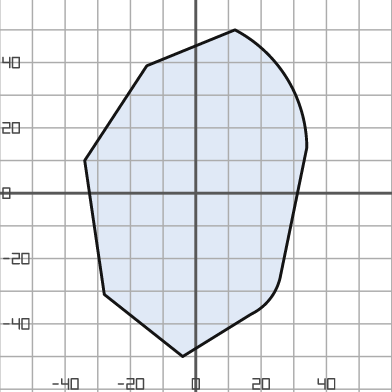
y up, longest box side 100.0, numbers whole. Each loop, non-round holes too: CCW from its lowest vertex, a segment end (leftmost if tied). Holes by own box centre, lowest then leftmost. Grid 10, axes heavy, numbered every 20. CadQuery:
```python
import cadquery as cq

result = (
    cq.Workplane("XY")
    .moveTo(-4.0, -50.0)
    .lineTo(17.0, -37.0)
    .threePointArc((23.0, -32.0), (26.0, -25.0))
    .lineTo(34.0, 14.0)
    .threePointArc((28.0, 35.0), (12.0, 50.0))
    .lineTo(-15.0, 39.0)
    .lineTo(-34.0, 10.0)
    .lineTo(-28.0, -31.0)
    .close()
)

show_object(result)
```